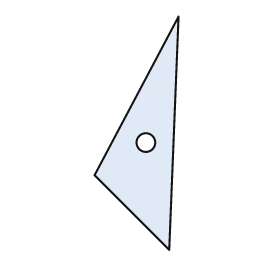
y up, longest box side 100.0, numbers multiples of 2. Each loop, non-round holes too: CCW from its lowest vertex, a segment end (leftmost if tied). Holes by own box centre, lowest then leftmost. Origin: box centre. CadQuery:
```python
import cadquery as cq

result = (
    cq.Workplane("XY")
    .moveTo(14.0, -50.0)
    .lineTo(18.0, 50.0)
    .lineTo(-18.0, -18.0)
    .close()
    .moveTo(4.0, -4.0)
    .circle(4.0)
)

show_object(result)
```